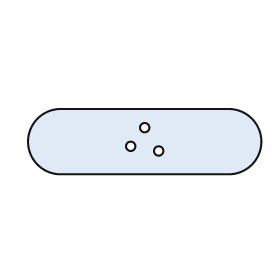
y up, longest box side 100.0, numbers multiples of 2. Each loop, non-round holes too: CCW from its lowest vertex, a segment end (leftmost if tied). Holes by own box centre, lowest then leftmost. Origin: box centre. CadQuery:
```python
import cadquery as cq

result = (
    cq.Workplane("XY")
    .moveTo(-36.0, -14.0)
    .lineTo(36.0, -14.0)
    .threePointArc((50.0, 0.0), (36.0, 14.0))
    .lineTo(-36.0, 14.0)
    .threePointArc((-50.0, 0.0), (-36.0, -14.0))
    .close()
    .moveTo(6.0, -4.0)
    .circle(2.0)
    .moveTo(-6.0, -2.0)
    .circle(2.0)
    .moveTo(0.0, 6.0)
    .circle(2.0)
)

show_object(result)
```